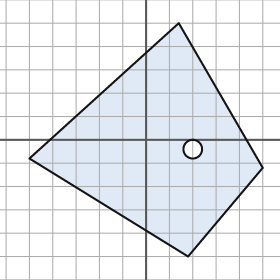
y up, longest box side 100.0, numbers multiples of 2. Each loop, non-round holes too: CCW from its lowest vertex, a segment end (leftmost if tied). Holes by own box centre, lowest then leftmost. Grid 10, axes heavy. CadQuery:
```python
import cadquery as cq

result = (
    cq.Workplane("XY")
    .moveTo(18.0, -50.0)
    .lineTo(50.0, -12.0)
    .lineTo(14.0, 50.0)
    .lineTo(-50.0, -8.0)
    .close()
    .moveTo(20.0, -4.0)
    .circle(4.0)
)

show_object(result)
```